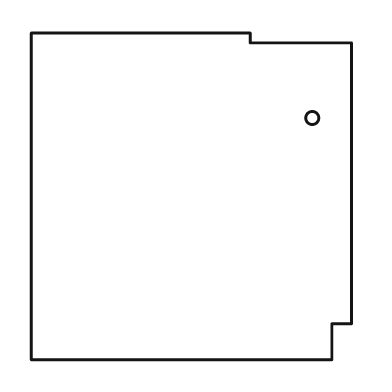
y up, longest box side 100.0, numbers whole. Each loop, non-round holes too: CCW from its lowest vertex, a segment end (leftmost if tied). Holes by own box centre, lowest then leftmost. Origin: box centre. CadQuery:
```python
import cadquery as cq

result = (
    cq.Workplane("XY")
    .moveTo(-49.0, -50.0)
    .lineTo(43.0, -50.0)
    .lineTo(43.0, -39.0)
    .lineTo(49.0, -39.0)
    .lineTo(49.0, 47.0)
    .lineTo(18.0, 47.0)
    .lineTo(18.0, 50.0)
    .lineTo(-49.0, 50.0)
    .close()
    .moveTo(37.0, 24.0)
    .circle(2.0)
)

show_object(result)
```